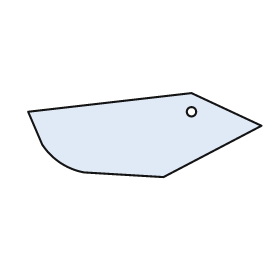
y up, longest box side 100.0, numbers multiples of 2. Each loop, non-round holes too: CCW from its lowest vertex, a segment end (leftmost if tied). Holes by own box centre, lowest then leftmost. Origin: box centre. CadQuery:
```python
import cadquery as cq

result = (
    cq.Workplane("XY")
    .moveTo(8.0, -18.0)
    .lineTo(50.0, 4.0)
    .lineTo(20.0, 18.0)
    .lineTo(-50.0, 10.0)
    .lineTo(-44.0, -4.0)
    .threePointArc((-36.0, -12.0), (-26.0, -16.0))
    .close()
    .moveTo(20.0, 10.0)
    .circle(2.0)
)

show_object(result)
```